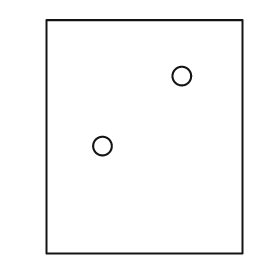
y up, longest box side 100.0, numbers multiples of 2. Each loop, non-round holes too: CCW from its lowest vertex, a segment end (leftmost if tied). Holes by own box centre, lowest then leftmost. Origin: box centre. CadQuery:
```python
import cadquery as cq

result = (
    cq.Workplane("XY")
    .moveTo(-42.0, -50.0)
    .lineTo(42.0, -50.0)
    .lineTo(42.0, 50.0)
    .lineTo(-42.0, 50.0)
    .close()
    .moveTo(-18.0, -4.0)
    .circle(4.0)
    .moveTo(16.0, 26.0)
    .circle(4.0)
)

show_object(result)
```